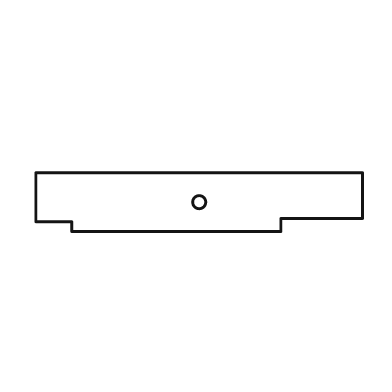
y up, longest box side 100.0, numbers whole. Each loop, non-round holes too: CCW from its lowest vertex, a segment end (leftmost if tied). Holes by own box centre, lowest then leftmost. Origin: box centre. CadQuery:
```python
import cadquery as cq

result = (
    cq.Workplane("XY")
    .moveTo(-39.0, -9.0)
    .lineTo(25.0, -9.0)
    .lineTo(25.0, -5.0)
    .lineTo(50.0, -5.0)
    .lineTo(50.0, 9.0)
    .lineTo(-50.0, 9.0)
    .lineTo(-50.0, -6.0)
    .lineTo(-39.0, -6.0)
    .close()
    .moveTo(0.0, 0.0)
    .circle(2.0)
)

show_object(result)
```